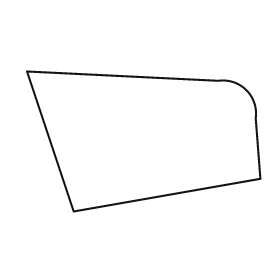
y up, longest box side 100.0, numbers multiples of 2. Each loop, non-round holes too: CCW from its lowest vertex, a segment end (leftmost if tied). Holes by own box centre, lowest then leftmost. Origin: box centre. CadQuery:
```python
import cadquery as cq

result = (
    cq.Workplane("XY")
    .moveTo(-30.0, -30.0)
    .lineTo(50.0, -16.0)
    .lineTo(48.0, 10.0)
    .threePointArc((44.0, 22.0), (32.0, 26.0))
    .lineTo(-50.0, 30.0)
    .close()
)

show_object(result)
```